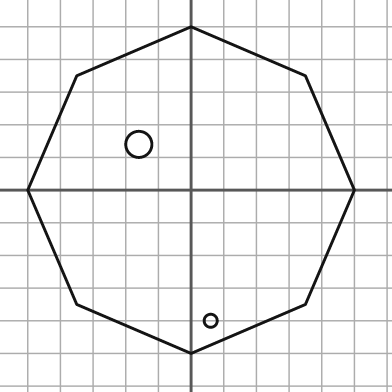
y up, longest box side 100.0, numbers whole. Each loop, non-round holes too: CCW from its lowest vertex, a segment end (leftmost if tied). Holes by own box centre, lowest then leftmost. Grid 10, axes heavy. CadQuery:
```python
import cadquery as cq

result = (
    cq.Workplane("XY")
    .moveTo(0.0, -50.0)
    .lineTo(35.0, -35.0)
    .lineTo(50.0, 0.0)
    .lineTo(35.0, 35.0)
    .lineTo(0.0, 50.0)
    .lineTo(-35.0, 35.0)
    .lineTo(-50.0, 0.0)
    .lineTo(-35.0, -35.0)
    .close()
    .moveTo(6.0, -40.0)
    .circle(2.0)
    .moveTo(-16.0, 14.0)
    .circle(4.0)
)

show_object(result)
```